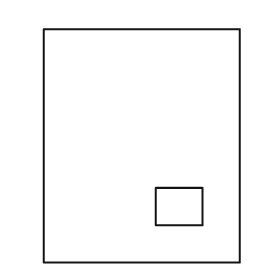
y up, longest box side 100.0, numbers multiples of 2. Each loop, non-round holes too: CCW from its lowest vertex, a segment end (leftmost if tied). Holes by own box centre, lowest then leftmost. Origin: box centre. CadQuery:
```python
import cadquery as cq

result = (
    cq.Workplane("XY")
    .moveTo(-42.0, -50.0)
    .lineTo(42.0, -50.0)
    .lineTo(42.0, 50.0)
    .lineTo(-42.0, 50.0)
    .close()
    .moveTo(6.0, -34.0)
    .lineTo(26.0, -34.0)
    .lineTo(26.0, -18.0)
    .lineTo(6.0, -18.0)
    .close()
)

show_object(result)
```